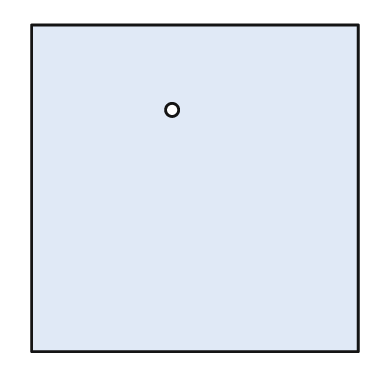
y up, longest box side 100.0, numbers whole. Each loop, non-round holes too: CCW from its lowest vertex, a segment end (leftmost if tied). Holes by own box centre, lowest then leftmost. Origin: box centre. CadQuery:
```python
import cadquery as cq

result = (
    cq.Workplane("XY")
    .moveTo(-50.0, -50.0)
    .lineTo(50.0, -50.0)
    .lineTo(50.0, 50.0)
    .lineTo(-50.0, 50.0)
    .close()
    .moveTo(-7.0, 24.0)
    .circle(2.0)
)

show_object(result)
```